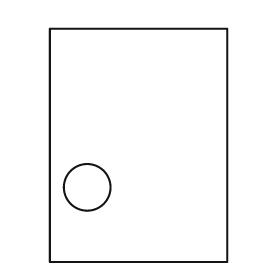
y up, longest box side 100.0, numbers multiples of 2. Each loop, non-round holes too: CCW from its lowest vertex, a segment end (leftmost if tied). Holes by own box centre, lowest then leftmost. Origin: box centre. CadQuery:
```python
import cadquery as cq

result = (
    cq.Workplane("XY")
    .moveTo(-38.0, -50.0)
    .lineTo(38.0, -50.0)
    .lineTo(38.0, 50.0)
    .lineTo(-38.0, 50.0)
    .close()
    .moveTo(-22.0, -18.0)
    .circle(10.0)
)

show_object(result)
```